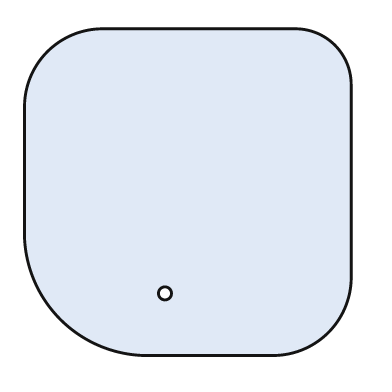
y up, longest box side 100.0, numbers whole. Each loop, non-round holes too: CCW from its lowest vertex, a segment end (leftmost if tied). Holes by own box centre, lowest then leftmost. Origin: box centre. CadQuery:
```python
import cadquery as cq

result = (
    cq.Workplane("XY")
    .moveTo(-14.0, -50.0)
    .lineTo(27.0, -50.0)
    .threePointArc((43.0, -43.0), (50.0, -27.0))
    .lineTo(50.0, 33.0)
    .threePointArc((45.0, 45.0), (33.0, 50.0))
    .lineTo(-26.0, 50.0)
    .threePointArc((-43.0, 43.0), (-50.0, 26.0))
    .lineTo(-50.0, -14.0)
    .threePointArc((-39.0, -39.0), (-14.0, -50.0))
    .close()
    .moveTo(-7.0, -31.0)
    .circle(2.0)
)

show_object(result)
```